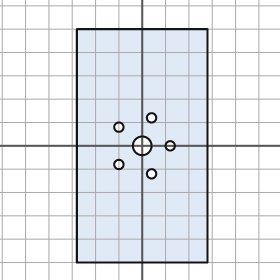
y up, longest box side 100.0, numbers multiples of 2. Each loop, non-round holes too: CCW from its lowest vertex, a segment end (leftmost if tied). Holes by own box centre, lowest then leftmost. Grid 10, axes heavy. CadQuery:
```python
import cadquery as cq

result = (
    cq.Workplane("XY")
    .moveTo(-28.0, -50.0)
    .lineTo(28.0, -50.0)
    .lineTo(28.0, 50.0)
    .lineTo(-28.0, 50.0)
    .close()
    .moveTo(4.0, -12.0)
    .circle(2.0)
    .moveTo(-10.0, -8.0)
    .circle(2.0)
    .moveTo(0.0, 0.0)
    .circle(4.0)
    .moveTo(12.0, 0.0)
    .circle(2.0)
    .moveTo(-10.0, 8.0)
    .circle(2.0)
    .moveTo(4.0, 12.0)
    .circle(2.0)
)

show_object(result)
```